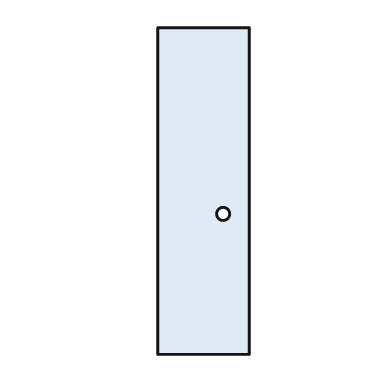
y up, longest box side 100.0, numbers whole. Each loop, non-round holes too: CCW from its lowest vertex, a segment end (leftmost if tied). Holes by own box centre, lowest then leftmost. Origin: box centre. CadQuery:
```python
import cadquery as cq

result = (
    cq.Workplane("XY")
    .moveTo(-14.0, -50.0)
    .lineTo(14.0, -50.0)
    .lineTo(14.0, 50.0)
    .lineTo(-14.0, 50.0)
    .close()
    .moveTo(6.0, -7.0)
    .circle(2.0)
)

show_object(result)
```